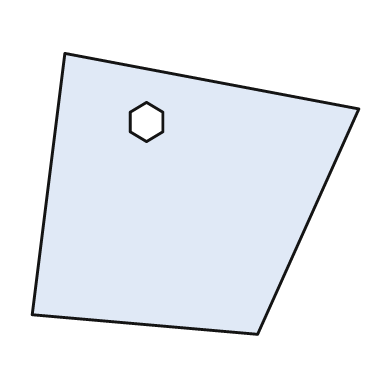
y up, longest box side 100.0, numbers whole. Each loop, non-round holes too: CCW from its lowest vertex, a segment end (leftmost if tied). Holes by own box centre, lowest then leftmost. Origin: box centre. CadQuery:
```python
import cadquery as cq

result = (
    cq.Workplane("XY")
    .moveTo(19.0, -43.0)
    .lineTo(50.0, 26.0)
    .lineTo(-40.0, 43.0)
    .lineTo(-50.0, -37.0)
    .close()
    .moveTo(-15.0, 16.0)
    .lineTo(-10.0, 19.0)
    .lineTo(-10.0, 25.0)
    .lineTo(-15.0, 28.0)
    .lineTo(-20.0, 25.0)
    .lineTo(-20.0, 19.0)
    .close()
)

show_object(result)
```